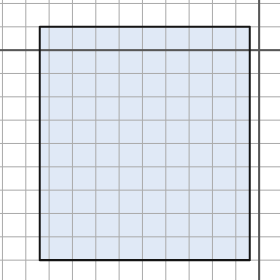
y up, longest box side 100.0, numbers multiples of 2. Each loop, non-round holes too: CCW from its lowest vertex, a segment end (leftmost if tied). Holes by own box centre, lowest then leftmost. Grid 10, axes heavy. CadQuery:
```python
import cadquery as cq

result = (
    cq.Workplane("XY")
    .moveTo(-94.0, -90.0)
    .lineTo(-4.0, -90.0)
    .lineTo(-4.0, 10.0)
    .lineTo(-94.0, 10.0)
    .close()
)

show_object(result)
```